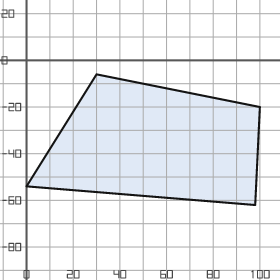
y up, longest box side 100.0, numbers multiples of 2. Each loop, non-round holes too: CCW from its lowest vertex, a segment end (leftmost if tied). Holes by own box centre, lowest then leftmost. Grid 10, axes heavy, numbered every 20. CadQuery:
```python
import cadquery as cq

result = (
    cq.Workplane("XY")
    .moveTo(98.0, -62.0)
    .lineTo(100.0, -20.0)
    .lineTo(30.0, -6.0)
    .lineTo(0.0, -54.0)
    .close()
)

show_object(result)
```